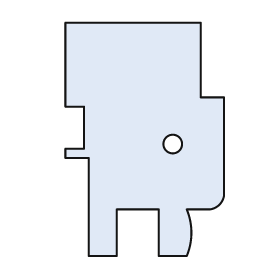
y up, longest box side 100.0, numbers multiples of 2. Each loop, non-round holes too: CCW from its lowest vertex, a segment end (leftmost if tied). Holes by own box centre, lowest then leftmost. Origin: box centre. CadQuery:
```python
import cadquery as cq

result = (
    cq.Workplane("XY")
    .moveTo(-24.0, -50.0)
    .lineTo(-12.0, -50.0)
    .lineTo(-12.0, -30.0)
    .lineTo(6.0, -30.0)
    .lineTo(6.0, -50.0)
    .lineTo(18.0, -50.0)
    .threePointArc((20.0, -40.0), (18.0, -30.0))
    .lineTo(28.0, -30.0)
    .threePointArc((32.0, -28.0), (34.0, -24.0))
    .lineTo(34.0, 18.0)
    .lineTo(24.0, 18.0)
    .lineTo(24.0, 50.0)
    .lineTo(-34.0, 50.0)
    .lineTo(-34.0, 14.0)
    .lineTo(-26.0, 14.0)
    .lineTo(-26.0, -4.0)
    .lineTo(-34.0, -4.0)
    .lineTo(-34.0, -8.0)
    .lineTo(-24.0, -8.0)
    .close()
    .moveTo(12.0, -2.0)
    .circle(4.0)
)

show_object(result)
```